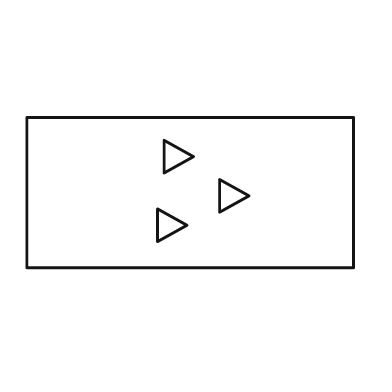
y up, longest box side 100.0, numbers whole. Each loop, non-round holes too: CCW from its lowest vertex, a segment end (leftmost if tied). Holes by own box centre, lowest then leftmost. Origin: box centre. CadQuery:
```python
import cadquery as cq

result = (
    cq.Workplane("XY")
    .moveTo(-50.0, -23.0)
    .lineTo(50.0, -23.0)
    .lineTo(50.0, 23.0)
    .lineTo(-50.0, 23.0)
    .close()
    .moveTo(-10.0, -15.0)
    .lineTo(-1.0, -10.0)
    .lineTo(-10.0, -5.0)
    .close()
    .moveTo(9.0, -6.0)
    .lineTo(18.0, -1.0)
    .lineTo(9.0, 4.0)
    .close()
    .moveTo(-8.0, 6.0)
    .lineTo(1.0, 11.0)
    .lineTo(-8.0, 16.0)
    .close()
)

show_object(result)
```